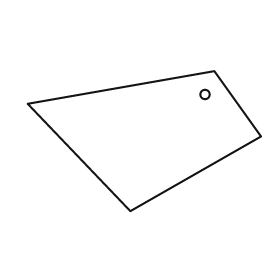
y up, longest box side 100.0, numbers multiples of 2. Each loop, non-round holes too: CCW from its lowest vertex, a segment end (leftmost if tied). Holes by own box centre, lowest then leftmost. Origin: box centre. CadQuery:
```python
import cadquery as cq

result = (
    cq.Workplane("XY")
    .moveTo(-6.0, -30.0)
    .lineTo(50.0, 2.0)
    .lineTo(30.0, 30.0)
    .lineTo(-50.0, 16.0)
    .close()
    .moveTo(26.0, 20.0)
    .circle(2.0)
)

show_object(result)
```